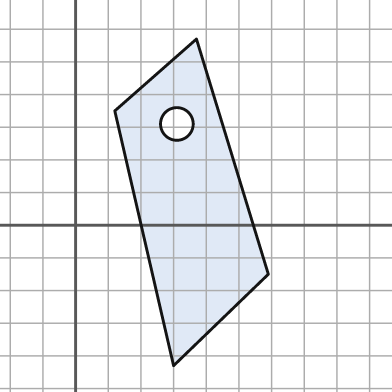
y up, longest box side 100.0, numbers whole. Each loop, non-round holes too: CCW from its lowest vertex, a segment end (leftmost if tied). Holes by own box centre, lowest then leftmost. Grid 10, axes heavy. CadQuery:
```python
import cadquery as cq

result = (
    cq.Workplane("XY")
    .moveTo(30.0, -43.0)
    .lineTo(59.0, -15.0)
    .lineTo(37.0, 57.0)
    .lineTo(12.0, 35.0)
    .close()
    .moveTo(31.0, 31.0)
    .circle(5.0)
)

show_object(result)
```